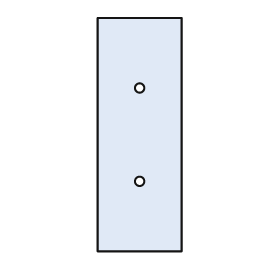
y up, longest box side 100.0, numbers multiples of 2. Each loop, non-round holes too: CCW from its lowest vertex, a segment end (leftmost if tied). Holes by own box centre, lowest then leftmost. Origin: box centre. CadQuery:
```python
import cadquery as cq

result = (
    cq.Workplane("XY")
    .moveTo(-18.0, -50.0)
    .lineTo(18.0, -50.0)
    .lineTo(18.0, 50.0)
    .lineTo(-18.0, 50.0)
    .close()
    .moveTo(0.0, -20.0)
    .circle(2.0)
    .moveTo(0.0, 20.0)
    .circle(2.0)
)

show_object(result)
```